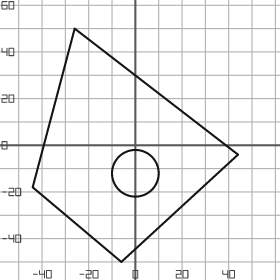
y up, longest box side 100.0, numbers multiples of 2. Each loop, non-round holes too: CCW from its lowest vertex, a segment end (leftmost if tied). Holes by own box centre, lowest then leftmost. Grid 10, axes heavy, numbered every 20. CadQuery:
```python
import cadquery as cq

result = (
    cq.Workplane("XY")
    .moveTo(-6.0, -50.0)
    .lineTo(44.0, -4.0)
    .lineTo(-26.0, 50.0)
    .lineTo(-44.0, -18.0)
    .close()
    .moveTo(0.0, -12.0)
    .circle(10.0)
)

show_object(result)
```